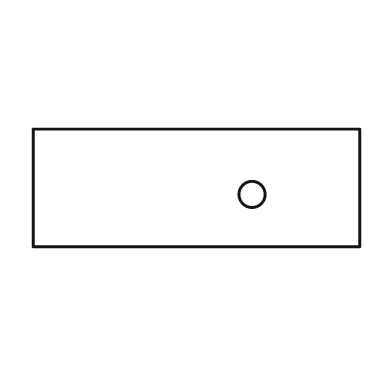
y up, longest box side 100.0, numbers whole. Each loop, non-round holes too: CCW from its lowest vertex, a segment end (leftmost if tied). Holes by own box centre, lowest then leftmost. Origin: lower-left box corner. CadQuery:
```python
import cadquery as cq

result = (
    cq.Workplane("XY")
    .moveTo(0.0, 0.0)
    .lineTo(100.0, 0.0)
    .lineTo(100.0, 36.0)
    .lineTo(0.0, 36.0)
    .close()
    .moveTo(67.0, 16.0)
    .circle(4.0)
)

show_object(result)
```